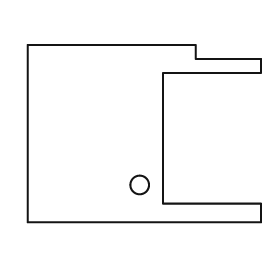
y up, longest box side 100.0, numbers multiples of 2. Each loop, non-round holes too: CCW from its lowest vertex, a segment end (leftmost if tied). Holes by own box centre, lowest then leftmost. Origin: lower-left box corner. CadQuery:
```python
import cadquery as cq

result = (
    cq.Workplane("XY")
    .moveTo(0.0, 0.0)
    .lineTo(100.0, 0.0)
    .lineTo(100.0, 8.0)
    .lineTo(58.0, 8.0)
    .lineTo(58.0, 64.0)
    .lineTo(100.0, 64.0)
    .lineTo(100.0, 70.0)
    .lineTo(72.0, 70.0)
    .lineTo(72.0, 76.0)
    .lineTo(0.0, 76.0)
    .close()
    .moveTo(48.0, 16.0)
    .circle(4.0)
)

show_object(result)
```